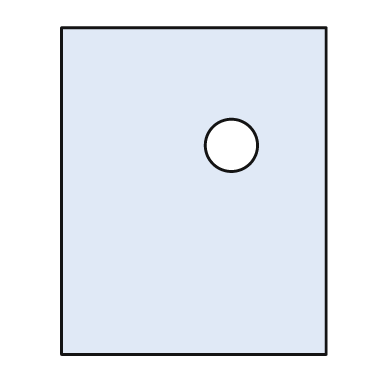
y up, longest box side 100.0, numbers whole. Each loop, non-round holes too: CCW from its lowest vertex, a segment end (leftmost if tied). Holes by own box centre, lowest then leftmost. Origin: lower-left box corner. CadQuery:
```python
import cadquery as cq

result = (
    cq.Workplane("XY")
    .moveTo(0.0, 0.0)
    .lineTo(81.0, 0.0)
    .lineTo(81.0, 100.0)
    .lineTo(0.0, 100.0)
    .close()
    .moveTo(52.0, 64.0)
    .circle(8.0)
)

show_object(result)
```